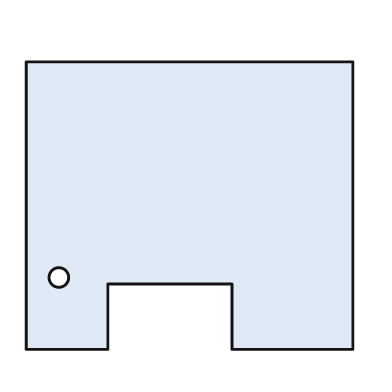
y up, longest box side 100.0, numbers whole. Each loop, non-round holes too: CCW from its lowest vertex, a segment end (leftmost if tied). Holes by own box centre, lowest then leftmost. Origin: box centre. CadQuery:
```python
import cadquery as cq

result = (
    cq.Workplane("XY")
    .moveTo(-50.0, -44.0)
    .lineTo(-25.0, -44.0)
    .lineTo(-25.0, -24.0)
    .lineTo(13.0, -24.0)
    .lineTo(13.0, -44.0)
    .lineTo(50.0, -44.0)
    .lineTo(50.0, 44.0)
    .lineTo(-50.0, 44.0)
    .close()
    .moveTo(-40.0, -22.0)
    .circle(3.0)
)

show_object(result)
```